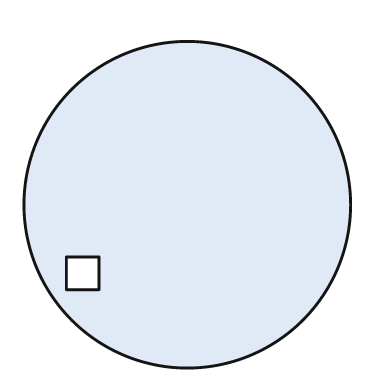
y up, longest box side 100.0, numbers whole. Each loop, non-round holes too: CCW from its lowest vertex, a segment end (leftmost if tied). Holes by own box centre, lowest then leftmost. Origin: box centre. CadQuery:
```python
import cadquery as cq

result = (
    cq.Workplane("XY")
    .moveTo(0.0, 0.0)
    .circle(50.0)
    .moveTo(-37.0, -26.0)
    .lineTo(-27.0, -26.0)
    .lineTo(-27.0, -16.0)
    .lineTo(-37.0, -16.0)
    .close()
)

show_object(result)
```